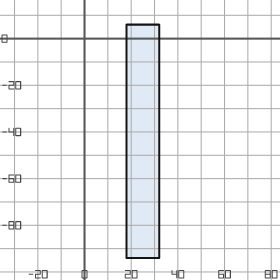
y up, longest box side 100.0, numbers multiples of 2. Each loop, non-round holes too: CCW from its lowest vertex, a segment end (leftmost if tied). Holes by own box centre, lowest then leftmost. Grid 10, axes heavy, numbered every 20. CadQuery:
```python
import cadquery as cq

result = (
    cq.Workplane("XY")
    .moveTo(18.0, -94.0)
    .lineTo(32.0, -94.0)
    .lineTo(32.0, 6.0)
    .lineTo(18.0, 6.0)
    .close()
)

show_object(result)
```